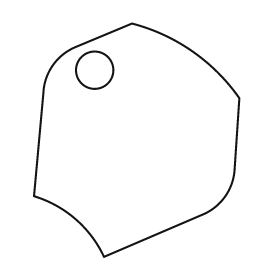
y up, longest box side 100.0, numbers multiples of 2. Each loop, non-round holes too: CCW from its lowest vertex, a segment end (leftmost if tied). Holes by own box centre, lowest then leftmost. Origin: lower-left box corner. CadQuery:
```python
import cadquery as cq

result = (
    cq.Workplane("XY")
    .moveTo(30.0, 0.0)
    .lineTo(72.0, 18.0)
    .threePointArc((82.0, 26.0), (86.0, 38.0))
    .lineTo(88.0, 68.0)
    .threePointArc((68.0, 88.0), (42.0, 100.0))
    .lineTo(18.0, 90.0)
    .threePointArc((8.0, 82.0), (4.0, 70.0))
    .lineTo(0.0, 26.0)
    .threePointArc((18.0, 16.0), (30.0, 0.0))
    .close()
    .moveTo(26.0, 80.0)
    .circle(8.0)
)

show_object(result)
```